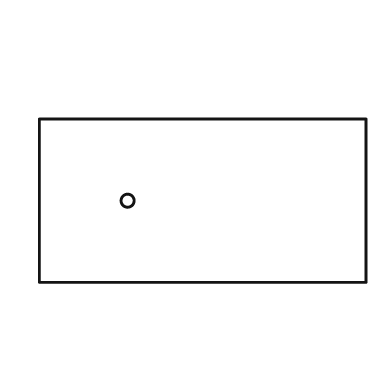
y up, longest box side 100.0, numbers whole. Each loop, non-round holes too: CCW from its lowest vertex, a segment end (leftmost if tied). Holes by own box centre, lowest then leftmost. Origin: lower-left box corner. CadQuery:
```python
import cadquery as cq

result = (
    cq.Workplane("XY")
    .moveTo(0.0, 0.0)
    .lineTo(100.0, 0.0)
    .lineTo(100.0, 50.0)
    .lineTo(0.0, 50.0)
    .close()
    .moveTo(27.0, 25.0)
    .circle(2.0)
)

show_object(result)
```